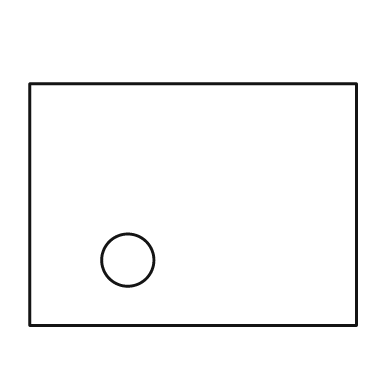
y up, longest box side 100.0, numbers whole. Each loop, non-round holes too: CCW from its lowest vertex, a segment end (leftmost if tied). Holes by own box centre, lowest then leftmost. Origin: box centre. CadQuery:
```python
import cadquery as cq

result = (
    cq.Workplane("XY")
    .moveTo(-50.0, -37.0)
    .lineTo(50.0, -37.0)
    .lineTo(50.0, 37.0)
    .lineTo(-50.0, 37.0)
    .close()
    .moveTo(-20.0, -17.0)
    .circle(8.0)
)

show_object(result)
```